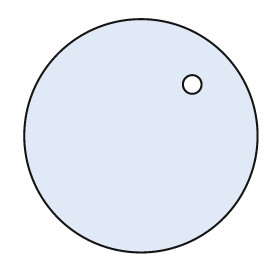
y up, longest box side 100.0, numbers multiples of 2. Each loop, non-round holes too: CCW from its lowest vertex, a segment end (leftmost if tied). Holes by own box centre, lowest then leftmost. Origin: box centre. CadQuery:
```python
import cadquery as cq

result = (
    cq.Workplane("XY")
    .moveTo(0.0, 0.0)
    .circle(50.0)
    .moveTo(22.0, 22.0)
    .circle(4.0)
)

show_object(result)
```